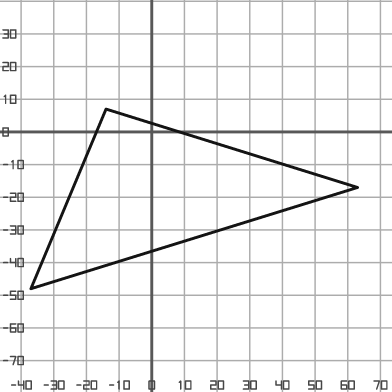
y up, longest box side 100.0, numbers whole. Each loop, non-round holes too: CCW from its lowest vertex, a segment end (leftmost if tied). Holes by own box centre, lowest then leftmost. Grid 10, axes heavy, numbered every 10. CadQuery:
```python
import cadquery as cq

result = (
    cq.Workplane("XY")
    .moveTo(-37.0, -48.0)
    .lineTo(63.0, -17.0)
    .lineTo(-14.0, 7.0)
    .close()
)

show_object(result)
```